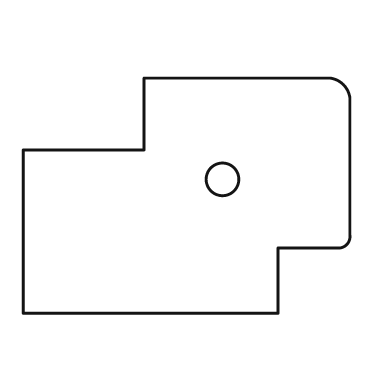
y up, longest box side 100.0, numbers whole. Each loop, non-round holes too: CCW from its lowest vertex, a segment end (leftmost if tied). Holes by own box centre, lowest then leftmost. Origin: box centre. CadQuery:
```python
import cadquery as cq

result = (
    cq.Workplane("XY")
    .moveTo(-50.0, -36.0)
    .lineTo(28.0, -36.0)
    .lineTo(28.0, -16.0)
    .lineTo(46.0, -16.0)
    .threePointArc((49.0, -15.0), (50.0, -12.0))
    .lineTo(50.0, 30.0)
    .threePointArc((48.0, 34.0), (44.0, 36.0))
    .lineTo(-13.0, 36.0)
    .lineTo(-13.0, 14.0)
    .lineTo(-50.0, 14.0)
    .close()
    .moveTo(11.0, 5.0)
    .circle(5.0)
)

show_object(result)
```